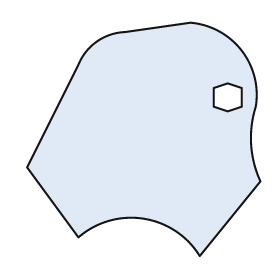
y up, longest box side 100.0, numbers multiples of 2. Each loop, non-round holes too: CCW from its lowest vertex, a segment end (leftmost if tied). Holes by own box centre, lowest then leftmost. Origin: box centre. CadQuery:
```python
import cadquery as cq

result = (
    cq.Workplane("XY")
    .moveTo(24.0, -50.0)
    .lineTo(50.0, -18.0)
    .threePointArc((46.0, -2.0), (48.0, 14.0))
    .threePointArc((42.0, 38.0), (20.0, 50.0))
    .lineTo(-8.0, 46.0)
    .threePointArc((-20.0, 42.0), (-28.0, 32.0))
    .lineTo(-50.0, -12.0)
    .lineTo(-28.0, -42.0)
    .threePointArc((0.0, -34.0), (24.0, -50.0))
    .close()
    .moveTo(36.0, 12.0)
    .lineTo(42.0, 14.0)
    .lineTo(42.0, 22.0)
    .lineTo(36.0, 24.0)
    .lineTo(30.0, 22.0)
    .lineTo(30.0, 14.0)
    .close()
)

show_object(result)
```